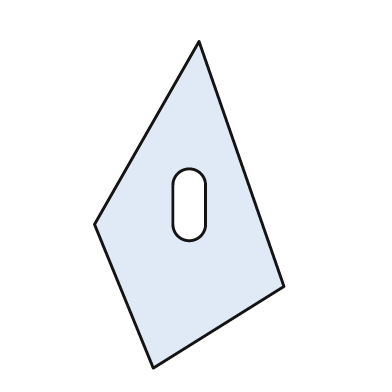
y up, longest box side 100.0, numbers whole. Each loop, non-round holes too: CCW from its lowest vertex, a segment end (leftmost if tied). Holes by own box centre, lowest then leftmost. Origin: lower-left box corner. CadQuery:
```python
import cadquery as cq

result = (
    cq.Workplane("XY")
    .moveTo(18.0, 0.0)
    .lineTo(58.0, 25.0)
    .lineTo(32.0, 100.0)
    .lineTo(0.0, 44.0)
    .close()
    .moveTo(24.0, 44.0)
    .threePointArc((29.0, 39.0), (34.0, 44.0))
    .lineTo(34.0, 56.0)
    .threePointArc((29.0, 61.0), (24.0, 56.0))
    .close()
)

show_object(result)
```